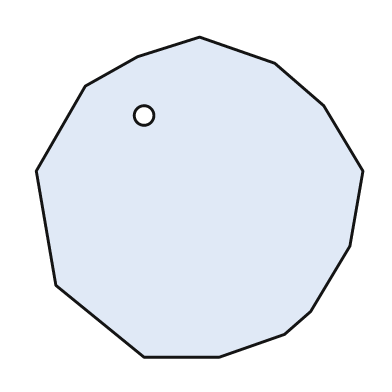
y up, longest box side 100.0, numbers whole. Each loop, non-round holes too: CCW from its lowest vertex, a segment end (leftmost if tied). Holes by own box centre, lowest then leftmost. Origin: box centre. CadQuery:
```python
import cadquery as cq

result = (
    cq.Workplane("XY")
    .moveTo(-17.0, -49.0)
    .lineTo(6.0, -49.0)
    .lineTo(26.0, -42.0)
    .lineTo(34.0, -35.0)
    .lineTo(46.0, -15.0)
    .lineTo(50.0, 8.0)
    .lineTo(38.0, 28.0)
    .lineTo(23.0, 41.0)
    .lineTo(0.0, 49.0)
    .lineTo(-19.0, 43.0)
    .lineTo(-35.0, 34.0)
    .lineTo(-50.0, 8.0)
    .lineTo(-44.0, -27.0)
    .close()
    .moveTo(-17.0, 25.0)
    .circle(3.0)
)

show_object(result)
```